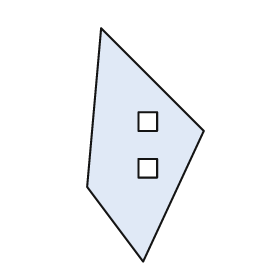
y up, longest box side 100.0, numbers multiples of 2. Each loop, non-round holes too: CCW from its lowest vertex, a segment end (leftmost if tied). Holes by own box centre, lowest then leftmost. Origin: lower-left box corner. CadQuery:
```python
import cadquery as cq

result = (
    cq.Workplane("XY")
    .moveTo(24.0, 0.0)
    .lineTo(50.0, 56.0)
    .lineTo(6.0, 100.0)
    .lineTo(0.0, 32.0)
    .close()
    .moveTo(22.0, 36.0)
    .lineTo(30.0, 36.0)
    .lineTo(30.0, 44.0)
    .lineTo(22.0, 44.0)
    .close()
    .moveTo(22.0, 56.0)
    .lineTo(30.0, 56.0)
    .lineTo(30.0, 64.0)
    .lineTo(22.0, 64.0)
    .close()
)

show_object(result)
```